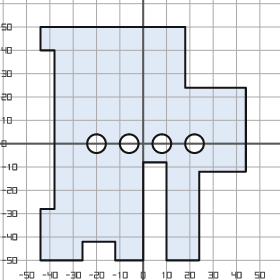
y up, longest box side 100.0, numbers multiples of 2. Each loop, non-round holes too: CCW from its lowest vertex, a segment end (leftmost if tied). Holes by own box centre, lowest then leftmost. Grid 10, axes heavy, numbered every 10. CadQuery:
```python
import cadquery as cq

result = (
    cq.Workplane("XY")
    .moveTo(-44.0, -50.0)
    .lineTo(-26.0, -50.0)
    .lineTo(-26.0, -42.0)
    .lineTo(-12.0, -42.0)
    .lineTo(-12.0, -50.0)
    .lineTo(0.0, -50.0)
    .lineTo(0.0, -8.0)
    .lineTo(10.0, -8.0)
    .lineTo(10.0, -50.0)
    .lineTo(24.0, -50.0)
    .lineTo(24.0, -12.0)
    .lineTo(44.0, -12.0)
    .lineTo(44.0, 24.0)
    .lineTo(18.0, 24.0)
    .lineTo(18.0, 50.0)
    .lineTo(-44.0, 50.0)
    .lineTo(-44.0, 40.0)
    .lineTo(-38.0, 40.0)
    .lineTo(-38.0, -28.0)
    .lineTo(-44.0, -28.0)
    .close()
    .moveTo(-20.0, 0.0)
    .circle(4.0)
    .moveTo(-6.0, 0.0)
    .circle(4.0)
    .moveTo(8.0, 0.0)
    .circle(4.0)
    .moveTo(22.0, 0.0)
    .circle(4.0)
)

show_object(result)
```